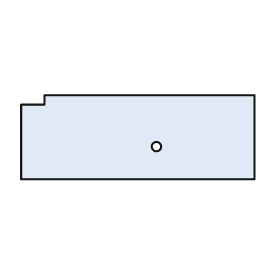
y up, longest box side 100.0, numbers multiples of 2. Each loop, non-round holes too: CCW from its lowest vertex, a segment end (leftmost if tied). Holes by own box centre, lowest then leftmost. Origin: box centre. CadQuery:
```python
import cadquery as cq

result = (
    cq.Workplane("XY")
    .moveTo(-50.0, -18.0)
    .lineTo(50.0, -18.0)
    .lineTo(50.0, 18.0)
    .lineTo(-40.0, 18.0)
    .lineTo(-40.0, 14.0)
    .lineTo(-50.0, 14.0)
    .close()
    .moveTo(8.0, -4.0)
    .circle(2.0)
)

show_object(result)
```